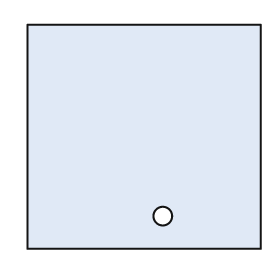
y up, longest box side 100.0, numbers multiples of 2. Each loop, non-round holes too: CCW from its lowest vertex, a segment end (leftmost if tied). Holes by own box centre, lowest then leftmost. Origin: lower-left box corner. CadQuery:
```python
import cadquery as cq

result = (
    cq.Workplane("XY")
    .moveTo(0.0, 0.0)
    .lineTo(100.0, 0.0)
    .lineTo(100.0, 96.0)
    .lineTo(0.0, 96.0)
    .close()
    .moveTo(58.0, 14.0)
    .circle(4.0)
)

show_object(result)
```